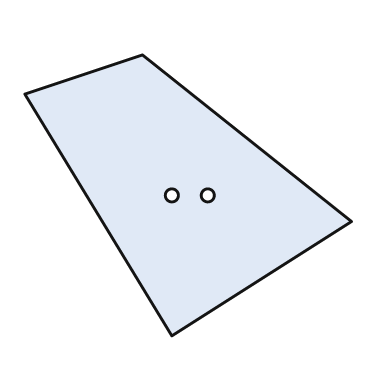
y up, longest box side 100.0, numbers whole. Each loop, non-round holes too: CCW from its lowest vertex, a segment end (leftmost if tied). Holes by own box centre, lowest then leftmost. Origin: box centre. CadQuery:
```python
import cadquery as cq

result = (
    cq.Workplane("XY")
    .moveTo(-5.0, -43.0)
    .lineTo(50.0, -8.0)
    .lineTo(-14.0, 43.0)
    .lineTo(-50.0, 31.0)
    .close()
    .moveTo(-5.0, 0.0)
    .circle(2.0)
    .moveTo(6.0, 0.0)
    .circle(2.0)
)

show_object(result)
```